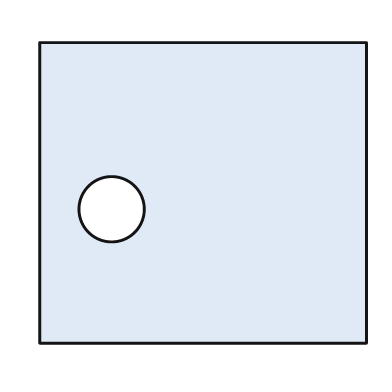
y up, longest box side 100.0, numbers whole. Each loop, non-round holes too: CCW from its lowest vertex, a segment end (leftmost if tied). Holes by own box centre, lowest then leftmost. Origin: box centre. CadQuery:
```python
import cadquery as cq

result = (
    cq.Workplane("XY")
    .moveTo(-50.0, -46.0)
    .lineTo(50.0, -46.0)
    .lineTo(50.0, 46.0)
    .lineTo(-50.0, 46.0)
    .close()
    .moveTo(-28.0, -5.0)
    .circle(10.0)
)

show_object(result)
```